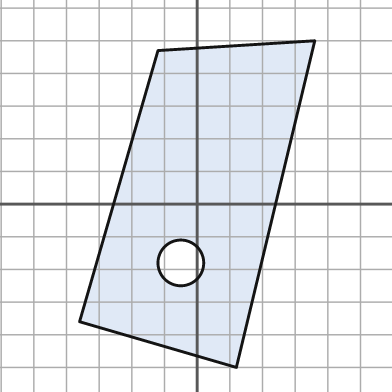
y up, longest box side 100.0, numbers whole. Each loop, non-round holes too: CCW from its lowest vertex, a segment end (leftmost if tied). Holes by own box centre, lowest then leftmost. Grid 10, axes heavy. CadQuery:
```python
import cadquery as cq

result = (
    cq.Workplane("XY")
    .moveTo(12.0, -50.0)
    .lineTo(36.0, 50.0)
    .lineTo(-12.0, 47.0)
    .lineTo(-36.0, -36.0)
    .close()
    .moveTo(-5.0, -18.0)
    .circle(7.0)
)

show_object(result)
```